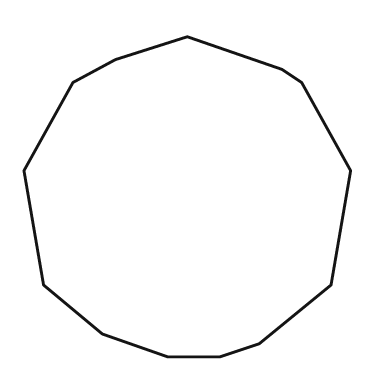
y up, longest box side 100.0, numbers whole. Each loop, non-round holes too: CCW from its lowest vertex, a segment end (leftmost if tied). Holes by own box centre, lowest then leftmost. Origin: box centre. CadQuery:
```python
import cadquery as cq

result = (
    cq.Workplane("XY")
    .moveTo(-6.0, -49.0)
    .lineTo(10.0, -49.0)
    .lineTo(22.0, -45.0)
    .lineTo(44.0, -27.0)
    .lineTo(50.0, 8.0)
    .lineTo(35.0, 35.0)
    .lineTo(29.0, 39.0)
    .lineTo(0.0, 49.0)
    .lineTo(-22.0, 42.0)
    .lineTo(-35.0, 35.0)
    .lineTo(-50.0, 8.0)
    .lineTo(-44.0, -27.0)
    .lineTo(-26.0, -42.0)
    .close()
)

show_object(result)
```